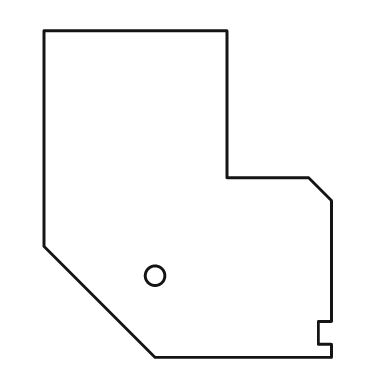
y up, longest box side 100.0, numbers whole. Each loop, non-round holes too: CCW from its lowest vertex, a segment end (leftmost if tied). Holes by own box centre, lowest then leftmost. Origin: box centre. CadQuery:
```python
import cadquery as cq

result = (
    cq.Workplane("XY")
    .moveTo(-10.0, -50.0)
    .lineTo(44.0, -50.0)
    .lineTo(44.0, -46.0)
    .lineTo(40.0, -46.0)
    .lineTo(40.0, -39.0)
    .lineTo(44.0, -39.0)
    .lineTo(44.0, -2.0)
    .lineTo(37.0, 5.0)
    .lineTo(12.0, 5.0)
    .lineTo(12.0, 50.0)
    .lineTo(-44.0, 50.0)
    .lineTo(-44.0, -16.0)
    .close()
    .moveTo(-10.0, -25.0)
    .circle(3.0)
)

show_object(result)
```